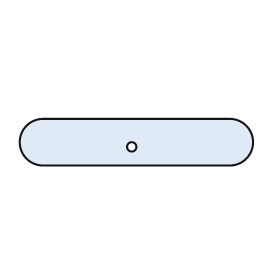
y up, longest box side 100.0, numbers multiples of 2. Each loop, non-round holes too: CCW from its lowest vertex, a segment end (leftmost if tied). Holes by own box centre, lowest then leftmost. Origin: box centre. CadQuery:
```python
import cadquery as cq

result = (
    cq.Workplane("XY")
    .moveTo(-40.0, -10.0)
    .lineTo(40.0, -10.0)
    .threePointArc((50.0, 0.0), (40.0, 10.0))
    .lineTo(-40.0, 10.0)
    .threePointArc((-50.0, 0.0), (-40.0, -10.0))
    .close()
    .moveTo(-2.0, -2.0)
    .circle(2.0)
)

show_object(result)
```